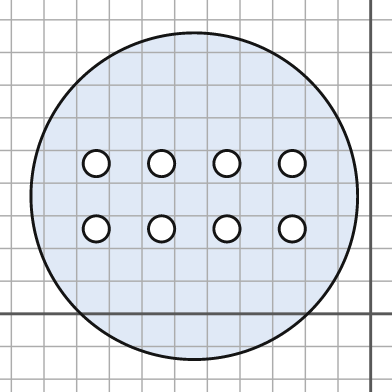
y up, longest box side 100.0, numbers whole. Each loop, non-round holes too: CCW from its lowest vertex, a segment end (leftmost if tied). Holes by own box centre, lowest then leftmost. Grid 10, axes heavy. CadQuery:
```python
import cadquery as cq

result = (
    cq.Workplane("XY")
    .moveTo(-54.0, 36.0)
    .circle(50.0)
    .moveTo(-84.0, 26.0)
    .circle(4.0)
    .moveTo(-64.0, 26.0)
    .circle(4.0)
    .moveTo(-44.0, 26.0)
    .circle(4.0)
    .moveTo(-24.0, 26.0)
    .circle(4.0)
    .moveTo(-84.0, 46.0)
    .circle(4.0)
    .moveTo(-64.0, 46.0)
    .circle(4.0)
    .moveTo(-44.0, 46.0)
    .circle(4.0)
    .moveTo(-24.0, 46.0)
    .circle(4.0)
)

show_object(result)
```